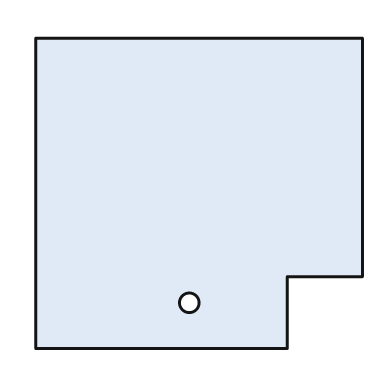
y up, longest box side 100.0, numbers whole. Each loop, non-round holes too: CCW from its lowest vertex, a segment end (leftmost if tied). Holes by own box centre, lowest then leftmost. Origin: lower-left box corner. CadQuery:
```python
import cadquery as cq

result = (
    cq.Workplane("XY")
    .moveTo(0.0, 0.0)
    .lineTo(77.0, 0.0)
    .lineTo(77.0, 22.0)
    .lineTo(100.0, 22.0)
    .lineTo(100.0, 95.0)
    .lineTo(0.0, 95.0)
    .close()
    .moveTo(47.0, 14.0)
    .circle(3.0)
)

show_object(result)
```